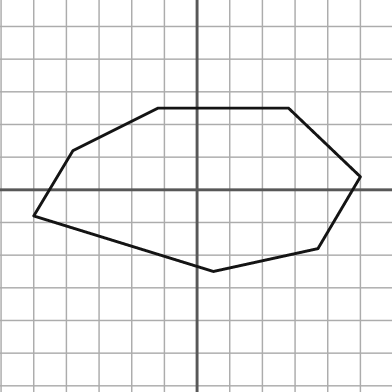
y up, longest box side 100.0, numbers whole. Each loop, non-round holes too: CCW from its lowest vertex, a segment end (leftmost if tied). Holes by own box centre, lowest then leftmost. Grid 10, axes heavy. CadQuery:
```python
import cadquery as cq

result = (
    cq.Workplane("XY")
    .moveTo(5.0, -25.0)
    .lineTo(37.0, -18.0)
    .lineTo(50.0, 4.0)
    .lineTo(28.0, 25.0)
    .lineTo(-12.0, 25.0)
    .lineTo(-38.0, 12.0)
    .lineTo(-50.0, -8.0)
    .close()
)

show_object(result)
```